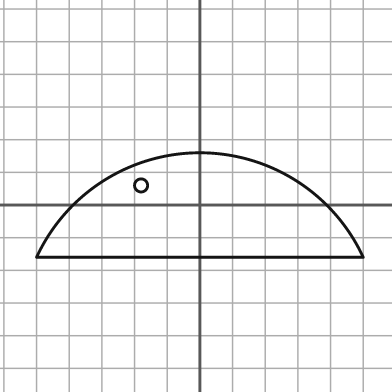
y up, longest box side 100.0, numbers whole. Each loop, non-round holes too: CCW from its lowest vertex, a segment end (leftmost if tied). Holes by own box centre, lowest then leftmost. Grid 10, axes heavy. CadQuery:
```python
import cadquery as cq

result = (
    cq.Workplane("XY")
    .moveTo(-50.0, -16.0)
    .lineTo(50.0, -16.0)
    .threePointArc((0.0, 16.0), (-50.0, -16.0))
    .close()
    .moveTo(-18.0, 6.0)
    .circle(2.0)
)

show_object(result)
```